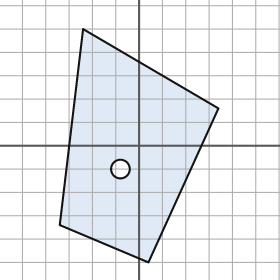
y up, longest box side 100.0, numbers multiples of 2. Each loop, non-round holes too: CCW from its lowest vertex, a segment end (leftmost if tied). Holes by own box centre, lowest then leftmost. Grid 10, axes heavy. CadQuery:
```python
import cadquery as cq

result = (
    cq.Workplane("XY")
    .moveTo(4.0, -50.0)
    .lineTo(34.0, 16.0)
    .lineTo(-24.0, 50.0)
    .lineTo(-34.0, -34.0)
    .close()
    .moveTo(-8.0, -10.0)
    .circle(4.0)
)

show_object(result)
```